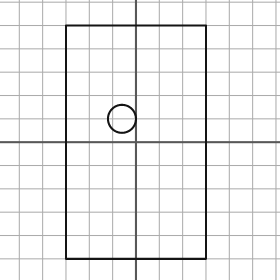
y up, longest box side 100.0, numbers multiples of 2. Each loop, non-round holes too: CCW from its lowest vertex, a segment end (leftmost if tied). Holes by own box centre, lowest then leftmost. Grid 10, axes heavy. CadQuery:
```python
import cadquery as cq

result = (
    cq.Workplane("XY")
    .moveTo(-30.0, -50.0)
    .lineTo(30.0, -50.0)
    .lineTo(30.0, 50.0)
    .lineTo(-30.0, 50.0)
    .close()
    .moveTo(-6.0, 10.0)
    .circle(6.0)
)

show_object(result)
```